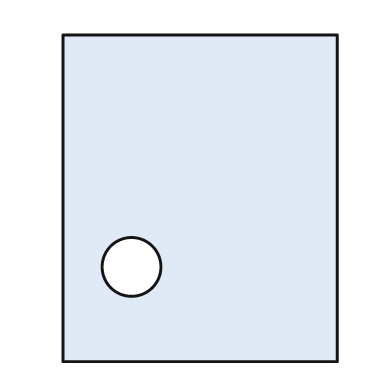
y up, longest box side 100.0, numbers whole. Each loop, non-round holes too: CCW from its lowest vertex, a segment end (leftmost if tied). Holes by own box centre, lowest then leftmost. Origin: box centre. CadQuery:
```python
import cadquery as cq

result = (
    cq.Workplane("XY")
    .moveTo(-42.0, -50.0)
    .lineTo(42.0, -50.0)
    .lineTo(42.0, 50.0)
    .lineTo(-42.0, 50.0)
    .close()
    .moveTo(-21.0, -21.0)
    .circle(9.0)
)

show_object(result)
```